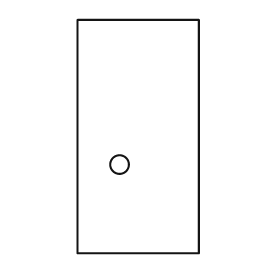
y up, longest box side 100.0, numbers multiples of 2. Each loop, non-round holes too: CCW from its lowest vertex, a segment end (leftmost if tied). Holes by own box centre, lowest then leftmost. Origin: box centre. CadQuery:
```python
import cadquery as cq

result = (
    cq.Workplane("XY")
    .moveTo(-26.0, -50.0)
    .lineTo(26.0, -50.0)
    .lineTo(26.0, 50.0)
    .lineTo(-26.0, 50.0)
    .close()
    .moveTo(-8.0, -12.0)
    .circle(4.0)
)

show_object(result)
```